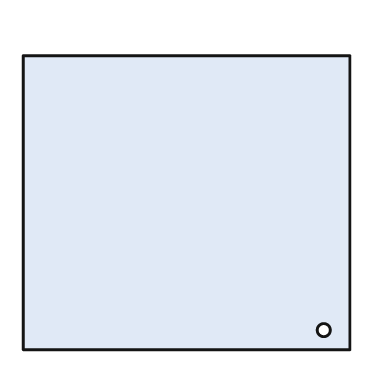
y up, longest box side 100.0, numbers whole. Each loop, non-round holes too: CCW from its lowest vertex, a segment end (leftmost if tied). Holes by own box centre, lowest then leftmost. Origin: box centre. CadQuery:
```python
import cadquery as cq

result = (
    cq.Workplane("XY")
    .moveTo(-50.0, -45.0)
    .lineTo(50.0, -45.0)
    .lineTo(50.0, 45.0)
    .lineTo(-50.0, 45.0)
    .close()
    .moveTo(42.0, -39.0)
    .circle(2.0)
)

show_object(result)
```